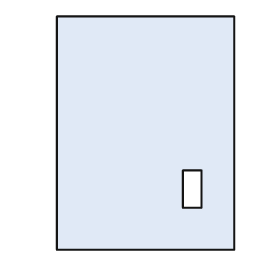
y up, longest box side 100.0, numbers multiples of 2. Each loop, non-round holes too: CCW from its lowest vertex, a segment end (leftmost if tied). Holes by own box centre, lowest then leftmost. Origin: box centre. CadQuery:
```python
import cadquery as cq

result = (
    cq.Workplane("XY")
    .moveTo(-38.0, -50.0)
    .lineTo(38.0, -50.0)
    .lineTo(38.0, 50.0)
    .lineTo(-38.0, 50.0)
    .close()
    .moveTo(16.0, -32.0)
    .lineTo(24.0, -32.0)
    .lineTo(24.0, -16.0)
    .lineTo(16.0, -16.0)
    .close()
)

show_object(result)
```